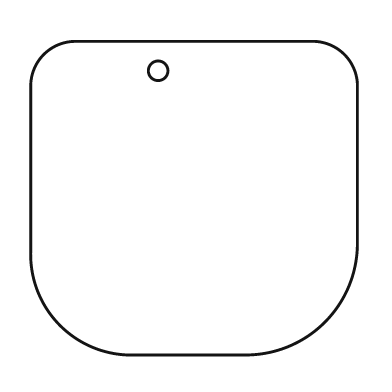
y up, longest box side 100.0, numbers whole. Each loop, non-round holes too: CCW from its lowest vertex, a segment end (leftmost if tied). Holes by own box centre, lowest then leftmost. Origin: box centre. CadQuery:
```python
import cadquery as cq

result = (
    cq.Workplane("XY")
    .moveTo(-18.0, -48.0)
    .lineTo(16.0, -48.0)
    .threePointArc((40.0, -38.0), (50.0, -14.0))
    .lineTo(50.0, 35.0)
    .threePointArc((46.0, 44.0), (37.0, 48.0))
    .lineTo(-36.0, 48.0)
    .threePointArc((-46.0, 44.0), (-50.0, 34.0))
    .lineTo(-50.0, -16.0)
    .threePointArc((-41.0, -39.0), (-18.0, -48.0))
    .close()
    .moveTo(-11.0, 39.0)
    .circle(3.0)
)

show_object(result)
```